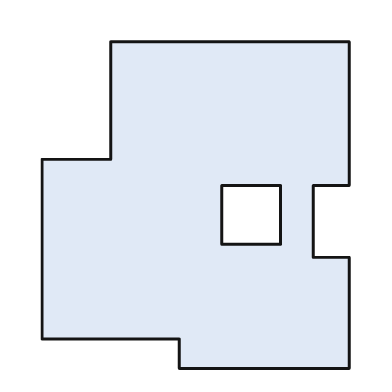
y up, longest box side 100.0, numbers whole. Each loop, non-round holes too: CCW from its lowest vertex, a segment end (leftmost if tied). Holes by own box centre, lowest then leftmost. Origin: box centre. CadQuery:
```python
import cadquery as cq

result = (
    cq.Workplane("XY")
    .moveTo(-5.0, -50.0)
    .lineTo(47.0, -50.0)
    .lineTo(47.0, -16.0)
    .lineTo(36.0, -16.0)
    .lineTo(36.0, 6.0)
    .lineTo(47.0, 6.0)
    .lineTo(47.0, 50.0)
    .lineTo(-26.0, 50.0)
    .lineTo(-26.0, 14.0)
    .lineTo(-47.0, 14.0)
    .lineTo(-47.0, -41.0)
    .lineTo(-5.0, -41.0)
    .close()
    .moveTo(8.0, -12.0)
    .lineTo(26.0, -12.0)
    .lineTo(26.0, 6.0)
    .lineTo(8.0, 6.0)
    .close()
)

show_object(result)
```